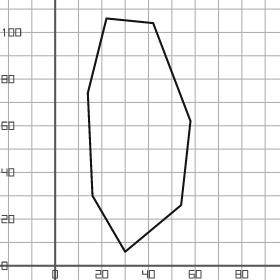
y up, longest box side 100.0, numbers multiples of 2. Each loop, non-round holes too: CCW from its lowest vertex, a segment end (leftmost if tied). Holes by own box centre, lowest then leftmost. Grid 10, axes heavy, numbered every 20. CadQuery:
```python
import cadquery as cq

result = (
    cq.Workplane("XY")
    .moveTo(30.0, 6.0)
    .lineTo(54.0, 26.0)
    .lineTo(58.0, 62.0)
    .lineTo(42.0, 104.0)
    .lineTo(22.0, 106.0)
    .lineTo(14.0, 74.0)
    .lineTo(16.0, 30.0)
    .close()
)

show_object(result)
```